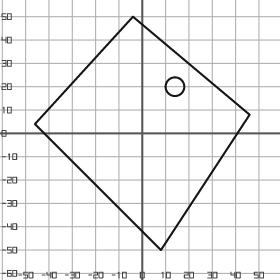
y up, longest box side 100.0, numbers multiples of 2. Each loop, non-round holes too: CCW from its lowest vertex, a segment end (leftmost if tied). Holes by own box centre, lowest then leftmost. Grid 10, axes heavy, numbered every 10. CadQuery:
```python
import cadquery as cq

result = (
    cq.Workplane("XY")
    .moveTo(8.0, -50.0)
    .lineTo(46.0, 8.0)
    .lineTo(-4.0, 50.0)
    .lineTo(-46.0, 4.0)
    .close()
    .moveTo(14.0, 20.0)
    .circle(4.0)
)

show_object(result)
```